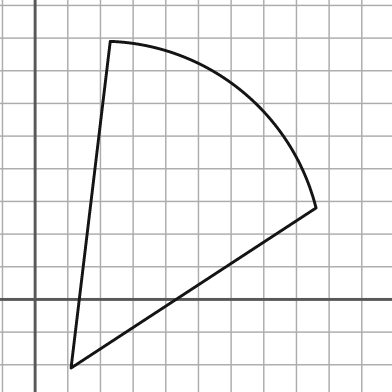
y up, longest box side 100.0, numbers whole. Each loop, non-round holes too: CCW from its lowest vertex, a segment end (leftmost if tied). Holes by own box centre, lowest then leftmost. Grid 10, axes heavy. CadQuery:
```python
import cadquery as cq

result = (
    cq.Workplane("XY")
    .moveTo(11.0, -21.0)
    .lineTo(86.0, 28.0)
    .threePointArc((63.0, 64.0), (23.0, 79.0))
    .close()
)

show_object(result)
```